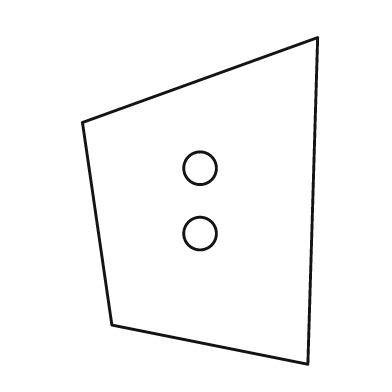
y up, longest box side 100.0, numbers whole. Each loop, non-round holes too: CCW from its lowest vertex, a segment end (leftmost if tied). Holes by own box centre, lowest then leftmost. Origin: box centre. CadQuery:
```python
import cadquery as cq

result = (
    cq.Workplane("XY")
    .moveTo(33.0, -50.0)
    .lineTo(36.0, 50.0)
    .lineTo(-36.0, 24.0)
    .lineTo(-27.0, -38.0)
    .close()
    .moveTo(0.0, -10.0)
    .circle(5.0)
    .moveTo(0.0, 10.0)
    .circle(5.0)
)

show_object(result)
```